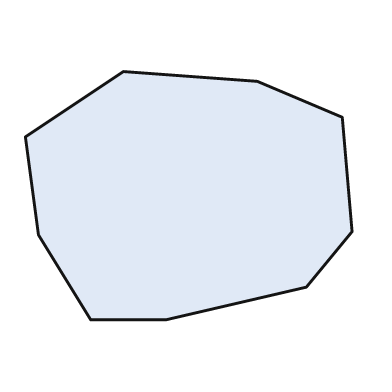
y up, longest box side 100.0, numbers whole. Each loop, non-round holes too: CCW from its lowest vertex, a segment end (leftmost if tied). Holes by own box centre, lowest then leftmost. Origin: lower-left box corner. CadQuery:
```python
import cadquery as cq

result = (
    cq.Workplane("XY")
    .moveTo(20.0, 0.0)
    .lineTo(43.0, 0.0)
    .lineTo(86.0, 10.0)
    .lineTo(100.0, 27.0)
    .lineTo(97.0, 62.0)
    .lineTo(71.0, 73.0)
    .lineTo(30.0, 76.0)
    .lineTo(0.0, 56.0)
    .lineTo(4.0, 26.0)
    .close()
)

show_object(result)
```